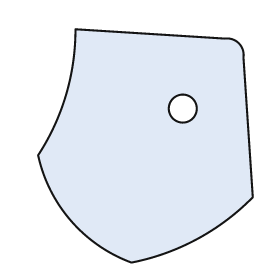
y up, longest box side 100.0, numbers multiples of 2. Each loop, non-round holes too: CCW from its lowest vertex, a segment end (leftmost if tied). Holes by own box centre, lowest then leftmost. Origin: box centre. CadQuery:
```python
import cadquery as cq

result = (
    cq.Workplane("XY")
    .moveTo(-6.0, -50.0)
    .threePointArc((22.0, -40.0), (46.0, -22.0))
    .lineTo(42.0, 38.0)
    .threePointArc((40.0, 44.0), (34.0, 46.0))
    .lineTo(-30.0, 50.0)
    .threePointArc((-34.0, 22.0), (-46.0, -4.0))
    .threePointArc((-32.0, -32.0), (-6.0, -50.0))
    .close()
    .moveTo(16.0, 16.0)
    .circle(6.0)
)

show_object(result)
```